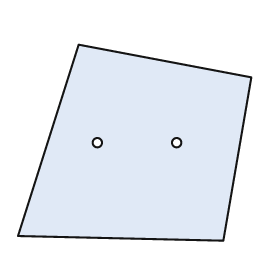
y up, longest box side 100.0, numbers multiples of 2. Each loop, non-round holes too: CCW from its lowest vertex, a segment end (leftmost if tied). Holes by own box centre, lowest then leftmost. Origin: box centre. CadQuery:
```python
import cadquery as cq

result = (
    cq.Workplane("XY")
    .moveTo(38.0, -42.0)
    .lineTo(50.0, 28.0)
    .lineTo(-24.0, 42.0)
    .lineTo(-50.0, -40.0)
    .close()
    .moveTo(-16.0, 0.0)
    .circle(2.0)
    .moveTo(18.0, 0.0)
    .circle(2.0)
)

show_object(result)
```